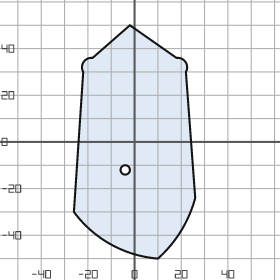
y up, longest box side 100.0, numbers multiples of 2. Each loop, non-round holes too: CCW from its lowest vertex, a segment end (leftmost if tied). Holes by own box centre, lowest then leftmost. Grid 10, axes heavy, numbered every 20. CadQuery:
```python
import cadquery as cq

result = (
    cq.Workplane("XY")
    .moveTo(10.0, -50.0)
    .threePointArc((20.0, -38.0), (26.0, -24.0))
    .lineTo(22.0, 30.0)
    .threePointArc((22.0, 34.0), (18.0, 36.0))
    .lineTo(-2.0, 50.0)
    .lineTo(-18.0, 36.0)
    .threePointArc((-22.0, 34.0), (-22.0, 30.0))
    .lineTo(-26.0, -30.0)
    .threePointArc((-10.0, -44.0), (10.0, -50.0))
    .close()
    .moveTo(-4.0, -12.0)
    .circle(2.0)
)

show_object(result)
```